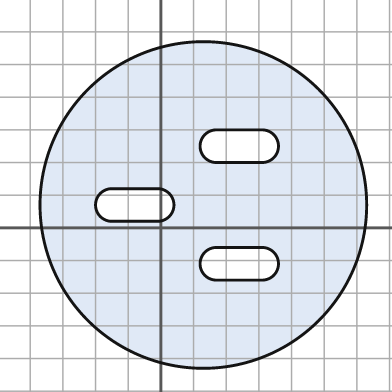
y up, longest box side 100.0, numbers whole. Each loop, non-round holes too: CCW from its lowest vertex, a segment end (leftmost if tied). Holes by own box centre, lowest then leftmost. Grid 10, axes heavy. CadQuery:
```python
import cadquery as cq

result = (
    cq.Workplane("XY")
    .moveTo(13.0, 7.0)
    .circle(50.0)
    .moveTo(17.0, -16.0)
    .lineTo(31.0, -16.0)
    .threePointArc((36.0, -11.0), (31.0, -6.0))
    .lineTo(17.0, -6.0)
    .threePointArc((12.0, -11.0), (17.0, -16.0))
    .close()
    .moveTo(-15.0, 2.0)
    .lineTo(-1.0, 2.0)
    .threePointArc((4.0, 7.0), (-1.0, 12.0))
    .lineTo(-15.0, 12.0)
    .threePointArc((-20.0, 7.0), (-15.0, 2.0))
    .close()
    .moveTo(17.0, 20.0)
    .lineTo(31.0, 20.0)
    .threePointArc((36.0, 25.0), (31.0, 30.0))
    .lineTo(17.0, 30.0)
    .threePointArc((12.0, 25.0), (17.0, 20.0))
    .close()
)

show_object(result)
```